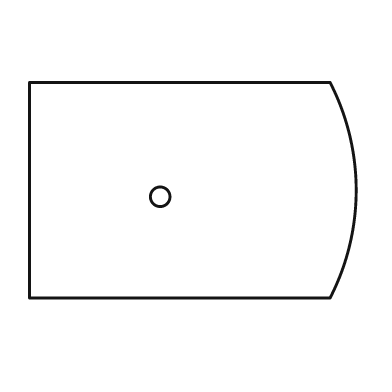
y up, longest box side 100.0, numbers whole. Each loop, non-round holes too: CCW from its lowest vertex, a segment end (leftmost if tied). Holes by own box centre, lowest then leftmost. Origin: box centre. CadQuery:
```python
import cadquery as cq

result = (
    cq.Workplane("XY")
    .moveTo(-50.0, -33.0)
    .lineTo(42.0, -33.0)
    .threePointArc((50.0, 0.0), (42.0, 33.0))
    .lineTo(-50.0, 33.0)
    .close()
    .moveTo(-10.0, -2.0)
    .circle(3.0)
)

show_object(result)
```